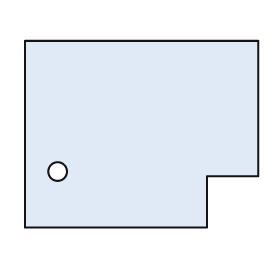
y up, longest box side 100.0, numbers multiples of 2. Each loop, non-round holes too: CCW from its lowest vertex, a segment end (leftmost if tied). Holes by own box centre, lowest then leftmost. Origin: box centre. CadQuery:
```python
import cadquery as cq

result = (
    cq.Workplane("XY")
    .moveTo(-50.0, -40.0)
    .lineTo(28.0, -40.0)
    .lineTo(28.0, -18.0)
    .lineTo(50.0, -18.0)
    .lineTo(50.0, 40.0)
    .lineTo(-50.0, 40.0)
    .close()
    .moveTo(-36.0, -16.0)
    .circle(4.0)
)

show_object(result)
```